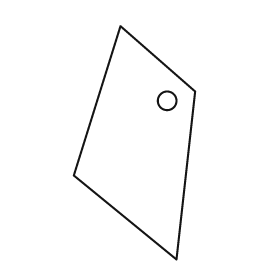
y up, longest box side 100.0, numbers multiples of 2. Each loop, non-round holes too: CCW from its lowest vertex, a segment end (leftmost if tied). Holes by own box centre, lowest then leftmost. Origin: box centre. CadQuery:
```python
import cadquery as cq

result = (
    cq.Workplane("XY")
    .moveTo(18.0, -50.0)
    .lineTo(26.0, 22.0)
    .lineTo(-6.0, 50.0)
    .lineTo(-26.0, -14.0)
    .close()
    .moveTo(14.0, 18.0)
    .circle(4.0)
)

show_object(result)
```